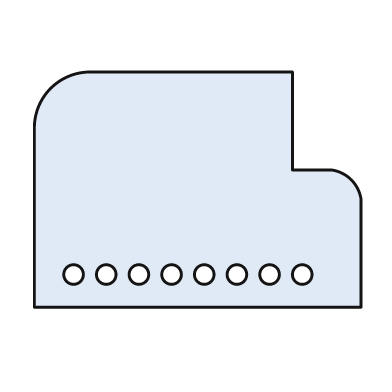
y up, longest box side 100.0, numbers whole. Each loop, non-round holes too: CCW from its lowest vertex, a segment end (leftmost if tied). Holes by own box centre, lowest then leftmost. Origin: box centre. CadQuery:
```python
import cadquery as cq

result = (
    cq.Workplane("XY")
    .moveTo(-50.0, -36.0)
    .lineTo(50.0, -36.0)
    .lineTo(50.0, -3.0)
    .threePointArc((47.0, 3.0), (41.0, 6.0))
    .lineTo(29.0, 6.0)
    .lineTo(29.0, 36.0)
    .lineTo(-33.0, 36.0)
    .threePointArc((-45.0, 31.0), (-50.0, 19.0))
    .close()
    .moveTo(-38.0, -26.0)
    .circle(3.0)
    .moveTo(-28.0, -26.0)
    .circle(3.0)
    .moveTo(-18.0, -26.0)
    .circle(3.0)
    .moveTo(-8.0, -26.0)
    .circle(3.0)
    .moveTo(2.0, -26.0)
    .circle(3.0)
    .moveTo(12.0, -26.0)
    .circle(3.0)
    .moveTo(22.0, -26.0)
    .circle(3.0)
    .moveTo(32.0, -26.0)
    .circle(3.0)
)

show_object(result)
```